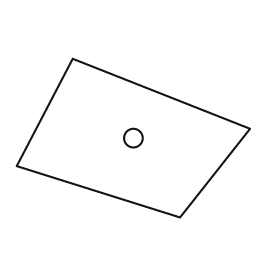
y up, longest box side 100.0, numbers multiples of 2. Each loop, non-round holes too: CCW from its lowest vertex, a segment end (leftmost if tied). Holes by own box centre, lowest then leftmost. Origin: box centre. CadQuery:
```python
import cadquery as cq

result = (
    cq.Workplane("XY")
    .moveTo(20.0, -34.0)
    .lineTo(50.0, 4.0)
    .lineTo(-26.0, 34.0)
    .lineTo(-50.0, -12.0)
    .close()
    .moveTo(0.0, 0.0)
    .circle(4.0)
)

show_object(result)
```